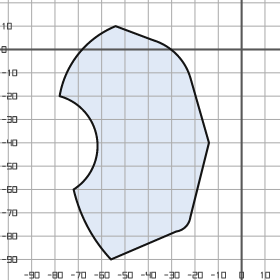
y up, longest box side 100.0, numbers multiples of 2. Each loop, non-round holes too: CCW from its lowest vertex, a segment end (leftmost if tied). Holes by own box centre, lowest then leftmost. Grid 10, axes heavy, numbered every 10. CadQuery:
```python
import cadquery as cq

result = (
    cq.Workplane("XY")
    .moveTo(-56.0, -90.0)
    .lineTo(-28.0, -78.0)
    .threePointArc((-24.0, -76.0), (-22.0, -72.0))
    .lineTo(-14.0, -40.0)
    .lineTo(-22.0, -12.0)
    .threePointArc((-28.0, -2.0), (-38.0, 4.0))
    .lineTo(-54.0, 10.0)
    .threePointArc((-70.0, -2.0), (-78.0, -20.0))
    .threePointArc((-62.0, -38.0), (-72.0, -60.0))
    .threePointArc((-66.0, -76.0), (-56.0, -90.0))
    .close()
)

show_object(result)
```